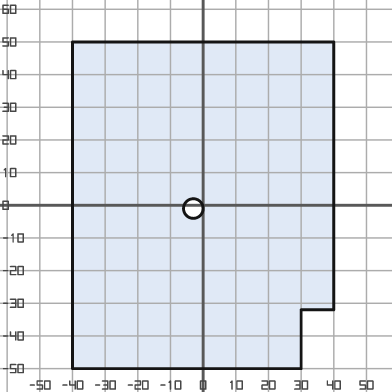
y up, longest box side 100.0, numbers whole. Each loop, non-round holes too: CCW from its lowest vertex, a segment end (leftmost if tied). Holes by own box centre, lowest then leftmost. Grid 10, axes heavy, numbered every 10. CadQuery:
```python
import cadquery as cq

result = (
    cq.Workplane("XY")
    .moveTo(-40.0, -50.0)
    .lineTo(30.0, -50.0)
    .lineTo(30.0, -32.0)
    .lineTo(40.0, -32.0)
    .lineTo(40.0, 50.0)
    .lineTo(-40.0, 50.0)
    .close()
    .moveTo(-3.0, -1.0)
    .circle(3.0)
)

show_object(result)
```